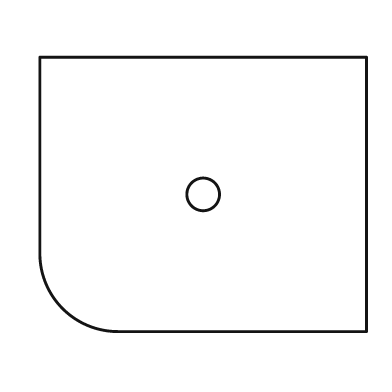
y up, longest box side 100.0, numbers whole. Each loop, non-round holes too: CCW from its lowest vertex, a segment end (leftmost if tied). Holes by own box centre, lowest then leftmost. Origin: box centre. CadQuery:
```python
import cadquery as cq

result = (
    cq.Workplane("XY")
    .moveTo(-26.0, -42.0)
    .lineTo(50.0, -42.0)
    .lineTo(50.0, 42.0)
    .lineTo(-50.0, 42.0)
    .lineTo(-50.0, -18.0)
    .threePointArc((-43.0, -35.0), (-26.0, -42.0))
    .close()
    .moveTo(0.0, 0.0)
    .circle(5.0)
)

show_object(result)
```